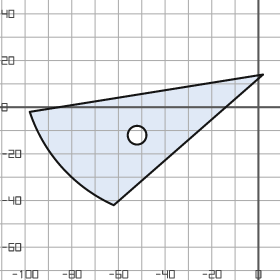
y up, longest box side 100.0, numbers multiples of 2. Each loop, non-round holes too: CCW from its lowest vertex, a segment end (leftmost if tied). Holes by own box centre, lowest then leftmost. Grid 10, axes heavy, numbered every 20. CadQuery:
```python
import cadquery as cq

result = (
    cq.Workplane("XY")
    .moveTo(-62.0, -42.0)
    .lineTo(2.0, 14.0)
    .lineTo(-98.0, -2.0)
    .threePointArc((-84.0, -26.0), (-62.0, -42.0))
    .close()
    .moveTo(-52.0, -12.0)
    .circle(4.0)
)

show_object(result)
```